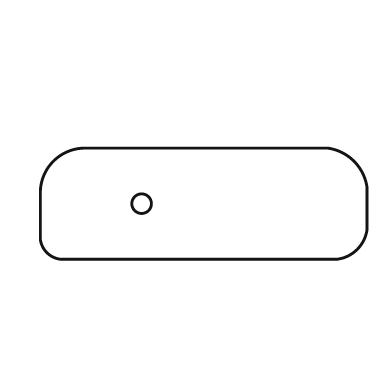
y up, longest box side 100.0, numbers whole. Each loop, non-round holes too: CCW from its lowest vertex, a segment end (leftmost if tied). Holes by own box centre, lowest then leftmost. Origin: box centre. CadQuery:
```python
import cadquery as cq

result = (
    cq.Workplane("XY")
    .moveTo(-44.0, -17.0)
    .lineTo(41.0, -17.0)
    .threePointArc((47.0, -14.0), (50.0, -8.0))
    .lineTo(50.0, 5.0)
    .threePointArc((46.0, 13.0), (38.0, 17.0))
    .lineTo(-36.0, 17.0)
    .threePointArc((-46.0, 13.0), (-50.0, 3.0))
    .lineTo(-50.0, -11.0)
    .threePointArc((-48.0, -15.0), (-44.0, -17.0))
    .close()
    .moveTo(-19.0, 0.0)
    .circle(3.0)
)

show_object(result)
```